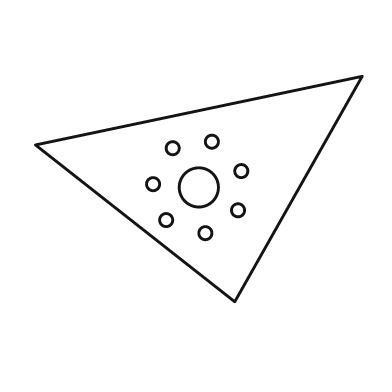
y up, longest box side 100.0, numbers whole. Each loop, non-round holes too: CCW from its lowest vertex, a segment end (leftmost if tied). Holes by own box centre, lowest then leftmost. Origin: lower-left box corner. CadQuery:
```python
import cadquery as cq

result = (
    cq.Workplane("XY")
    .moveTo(61.0, 0.0)
    .lineTo(100.0, 69.0)
    .lineTo(0.0, 48.0)
    .close()
    .moveTo(52.0, 21.0)
    .circle(2.0)
    .moveTo(40.0, 25.0)
    .circle(2.0)
    .moveTo(62.0, 28.0)
    .circle(2.0)
    .moveTo(50.0, 35.0)
    .circle(6.0)
    .moveTo(36.0, 36.0)
    .circle(2.0)
    .moveTo(63.0, 40.0)
    .circle(2.0)
    .moveTo(42.0, 47.0)
    .circle(2.0)
    .moveTo(54.0, 49.0)
    .circle(2.0)
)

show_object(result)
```